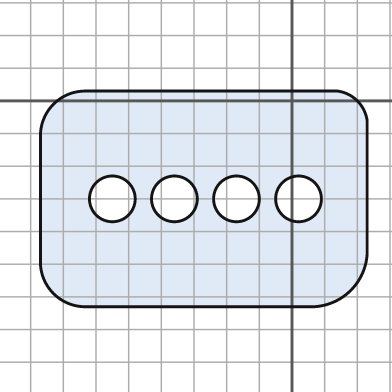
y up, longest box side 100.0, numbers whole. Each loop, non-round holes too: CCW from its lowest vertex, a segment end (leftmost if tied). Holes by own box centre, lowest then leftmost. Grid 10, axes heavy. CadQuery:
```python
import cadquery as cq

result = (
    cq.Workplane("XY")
    .moveTo(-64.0, -63.0)
    .lineTo(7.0, -63.0)
    .threePointArc((18.0, -58.0), (23.0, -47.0))
    .lineTo(23.0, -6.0)
    .threePointArc((20.0, 0.0), (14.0, 3.0))
    .lineTo(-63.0, 3.0)
    .threePointArc((-73.0, -1.0), (-77.0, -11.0))
    .lineTo(-77.0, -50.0)
    .threePointArc((-73.0, -59.0), (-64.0, -63.0))
    .close()
    .moveTo(-55.0, -30.0)
    .circle(7.0)
    .moveTo(-36.0, -30.0)
    .circle(7.0)
    .moveTo(-17.0, -30.0)
    .circle(7.0)
    .moveTo(2.0, -30.0)
    .circle(7.0)
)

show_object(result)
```